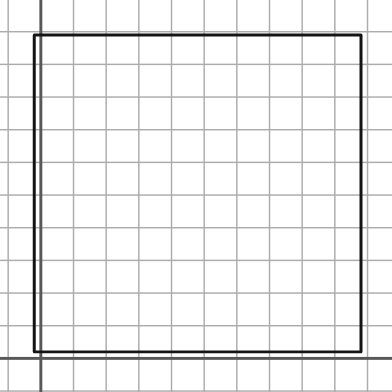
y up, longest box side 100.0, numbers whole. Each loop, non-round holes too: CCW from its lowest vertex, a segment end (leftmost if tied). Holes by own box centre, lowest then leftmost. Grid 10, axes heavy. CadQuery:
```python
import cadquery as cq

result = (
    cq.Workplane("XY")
    .moveTo(-2.0, 2.0)
    .lineTo(98.0, 2.0)
    .lineTo(98.0, 99.0)
    .lineTo(-2.0, 99.0)
    .close()
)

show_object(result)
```